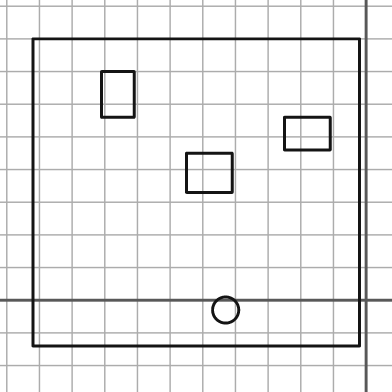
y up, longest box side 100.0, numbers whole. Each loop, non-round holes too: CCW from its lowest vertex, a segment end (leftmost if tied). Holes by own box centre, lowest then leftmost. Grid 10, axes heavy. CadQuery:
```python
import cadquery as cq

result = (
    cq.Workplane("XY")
    .moveTo(-102.0, -14.0)
    .lineTo(-2.0, -14.0)
    .lineTo(-2.0, 80.0)
    .lineTo(-102.0, 80.0)
    .close()
    .moveTo(-43.0, -3.0)
    .circle(4.0)
    .moveTo(-55.0, 33.0)
    .lineTo(-41.0, 33.0)
    .lineTo(-41.0, 45.0)
    .lineTo(-55.0, 45.0)
    .close()
    .moveTo(-25.0, 46.0)
    .lineTo(-11.0, 46.0)
    .lineTo(-11.0, 56.0)
    .lineTo(-25.0, 56.0)
    .close()
    .moveTo(-81.0, 56.0)
    .lineTo(-71.0, 56.0)
    .lineTo(-71.0, 70.0)
    .lineTo(-81.0, 70.0)
    .close()
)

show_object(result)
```